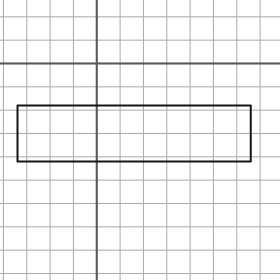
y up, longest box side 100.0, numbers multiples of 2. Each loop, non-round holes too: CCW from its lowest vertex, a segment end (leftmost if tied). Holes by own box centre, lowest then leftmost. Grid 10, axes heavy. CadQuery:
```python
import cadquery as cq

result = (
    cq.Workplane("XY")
    .moveTo(-34.0, -42.0)
    .lineTo(66.0, -42.0)
    .lineTo(66.0, -18.0)
    .lineTo(-34.0, -18.0)
    .close()
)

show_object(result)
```